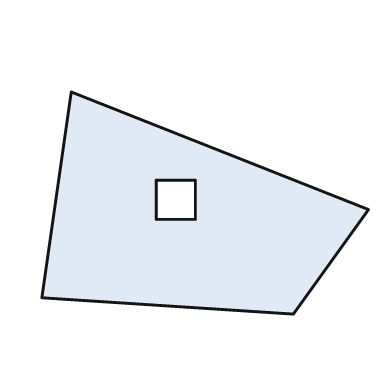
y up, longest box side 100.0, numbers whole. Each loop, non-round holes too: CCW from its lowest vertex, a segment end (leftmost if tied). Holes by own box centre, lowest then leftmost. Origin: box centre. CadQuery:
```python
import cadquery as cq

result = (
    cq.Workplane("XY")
    .moveTo(27.0, -34.0)
    .lineTo(50.0, -2.0)
    .lineTo(-41.0, 34.0)
    .lineTo(-50.0, -29.0)
    .close()
    .moveTo(-15.0, -5.0)
    .lineTo(-3.0, -5.0)
    .lineTo(-3.0, 7.0)
    .lineTo(-15.0, 7.0)
    .close()
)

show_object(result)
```